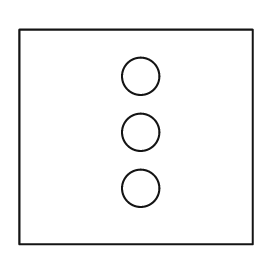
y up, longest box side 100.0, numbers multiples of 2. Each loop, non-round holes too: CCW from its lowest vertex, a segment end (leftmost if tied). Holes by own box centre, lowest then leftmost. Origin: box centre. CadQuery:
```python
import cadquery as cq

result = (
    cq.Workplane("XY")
    .moveTo(-50.0, -46.0)
    .lineTo(50.0, -46.0)
    .lineTo(50.0, 46.0)
    .lineTo(-50.0, 46.0)
    .close()
    .moveTo(2.0, -22.0)
    .circle(8.0)
    .moveTo(2.0, 2.0)
    .circle(8.0)
    .moveTo(2.0, 26.0)
    .circle(8.0)
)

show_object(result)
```